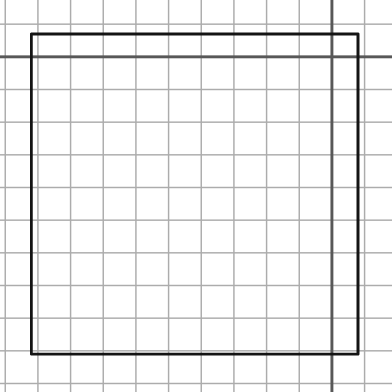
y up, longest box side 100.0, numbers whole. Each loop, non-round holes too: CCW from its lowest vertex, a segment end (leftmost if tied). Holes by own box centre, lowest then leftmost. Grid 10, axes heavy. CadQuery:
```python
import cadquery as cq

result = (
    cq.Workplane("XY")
    .moveTo(-92.0, -91.0)
    .lineTo(8.0, -91.0)
    .lineTo(8.0, 7.0)
    .lineTo(-92.0, 7.0)
    .close()
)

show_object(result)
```